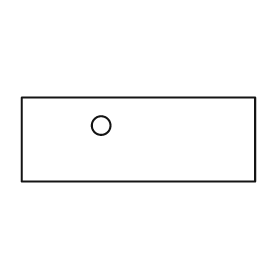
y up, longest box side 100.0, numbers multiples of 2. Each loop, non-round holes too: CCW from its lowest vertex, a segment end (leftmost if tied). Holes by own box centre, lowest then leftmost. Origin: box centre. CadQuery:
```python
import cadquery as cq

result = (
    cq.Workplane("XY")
    .moveTo(-50.0, -18.0)
    .lineTo(50.0, -18.0)
    .lineTo(50.0, 18.0)
    .lineTo(-50.0, 18.0)
    .close()
    .moveTo(-16.0, 6.0)
    .circle(4.0)
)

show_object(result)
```